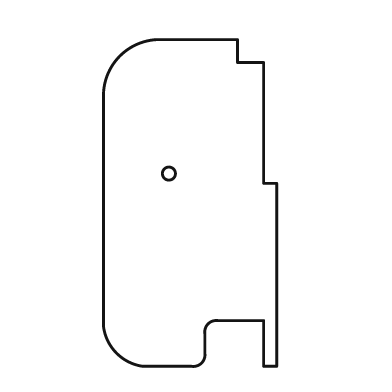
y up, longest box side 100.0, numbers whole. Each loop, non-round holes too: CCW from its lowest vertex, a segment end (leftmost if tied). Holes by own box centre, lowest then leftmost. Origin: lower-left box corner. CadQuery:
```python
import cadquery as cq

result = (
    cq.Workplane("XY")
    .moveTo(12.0, 0.0)
    .lineTo(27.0, 0.0)
    .threePointArc((30.0, 1.0), (31.0, 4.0))
    .lineTo(31.0, 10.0)
    .threePointArc((32.0, 13.0), (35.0, 14.0))
    .lineTo(49.0, 14.0)
    .lineTo(49.0, 0.0)
    .lineTo(53.0, 0.0)
    .lineTo(53.0, 56.0)
    .lineTo(49.0, 56.0)
    .lineTo(49.0, 93.0)
    .lineTo(41.0, 93.0)
    .lineTo(41.0, 100.0)
    .lineTo(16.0, 100.0)
    .threePointArc((5.0, 95.0), (0.0, 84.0))
    .lineTo(0.0, 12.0)
    .threePointArc((4.0, 4.0), (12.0, 0.0))
    .close()
    .moveTo(20.0, 59.0)
    .circle(2.0)
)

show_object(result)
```